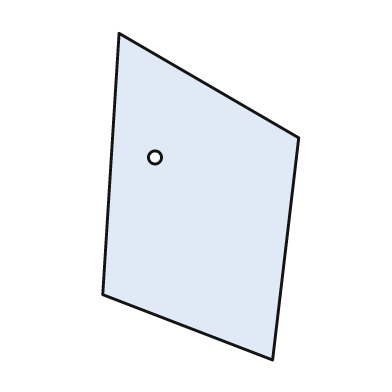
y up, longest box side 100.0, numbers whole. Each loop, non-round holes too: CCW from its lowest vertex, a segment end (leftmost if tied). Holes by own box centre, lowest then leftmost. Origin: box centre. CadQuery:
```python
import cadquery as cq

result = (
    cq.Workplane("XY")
    .moveTo(22.0, -50.0)
    .lineTo(30.0, 18.0)
    .lineTo(-25.0, 50.0)
    .lineTo(-30.0, -30.0)
    .close()
    .moveTo(-14.0, 12.0)
    .circle(2.0)
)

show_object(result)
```